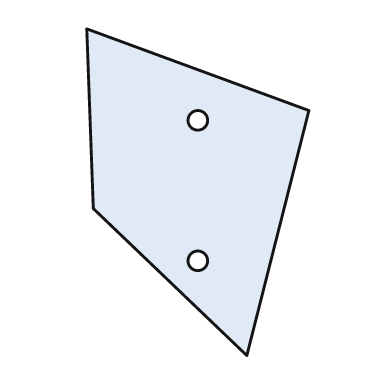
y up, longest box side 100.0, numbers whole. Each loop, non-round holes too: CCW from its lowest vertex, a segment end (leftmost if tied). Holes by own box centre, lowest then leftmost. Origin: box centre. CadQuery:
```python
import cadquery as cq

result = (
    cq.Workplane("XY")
    .moveTo(15.0, -50.0)
    .lineTo(34.0, 25.0)
    .lineTo(-34.0, 50.0)
    .lineTo(-32.0, -5.0)
    .close()
    .moveTo(0.0, -21.0)
    .circle(3.0)
    .moveTo(0.0, 22.0)
    .circle(3.0)
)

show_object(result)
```